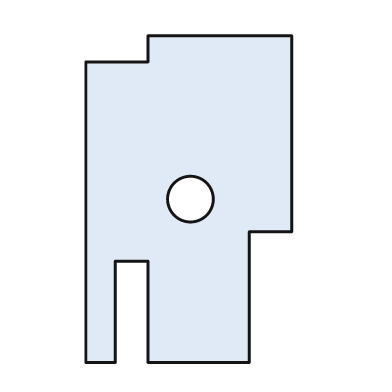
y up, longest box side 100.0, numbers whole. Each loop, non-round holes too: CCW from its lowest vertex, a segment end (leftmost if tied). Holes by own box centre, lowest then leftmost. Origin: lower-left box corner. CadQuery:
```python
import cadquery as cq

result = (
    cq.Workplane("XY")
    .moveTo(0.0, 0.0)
    .lineTo(9.0, 0.0)
    .lineTo(9.0, 31.0)
    .lineTo(19.0, 31.0)
    .lineTo(19.0, 0.0)
    .lineTo(50.0, 0.0)
    .lineTo(50.0, 40.0)
    .lineTo(63.0, 40.0)
    .lineTo(63.0, 100.0)
    .lineTo(19.0, 100.0)
    .lineTo(19.0, 92.0)
    .lineTo(0.0, 92.0)
    .close()
    .moveTo(32.0, 50.0)
    .circle(7.0)
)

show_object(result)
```